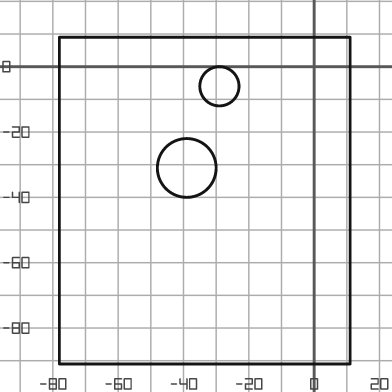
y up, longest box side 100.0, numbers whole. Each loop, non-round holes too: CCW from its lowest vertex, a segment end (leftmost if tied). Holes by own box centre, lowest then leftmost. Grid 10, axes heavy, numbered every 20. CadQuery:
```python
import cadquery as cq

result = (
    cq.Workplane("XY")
    .moveTo(-78.0, -91.0)
    .lineTo(11.0, -91.0)
    .lineTo(11.0, 9.0)
    .lineTo(-78.0, 9.0)
    .close()
    .moveTo(-39.0, -31.0)
    .circle(9.0)
    .moveTo(-29.0, -6.0)
    .circle(6.0)
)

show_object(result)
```